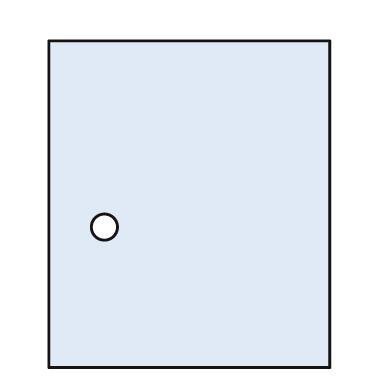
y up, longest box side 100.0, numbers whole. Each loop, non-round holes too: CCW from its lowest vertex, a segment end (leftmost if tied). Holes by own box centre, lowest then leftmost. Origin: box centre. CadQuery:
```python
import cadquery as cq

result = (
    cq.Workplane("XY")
    .moveTo(-43.0, -50.0)
    .lineTo(43.0, -50.0)
    .lineTo(43.0, 50.0)
    .lineTo(-43.0, 50.0)
    .close()
    .moveTo(-26.0, -7.0)
    .circle(4.0)
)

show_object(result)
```